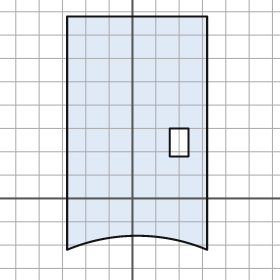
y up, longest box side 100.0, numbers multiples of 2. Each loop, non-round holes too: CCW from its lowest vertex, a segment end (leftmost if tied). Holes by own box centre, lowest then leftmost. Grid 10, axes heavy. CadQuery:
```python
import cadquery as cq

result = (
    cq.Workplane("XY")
    .moveTo(-28.0, -22.0)
    .threePointArc((2.0, -16.0), (32.0, -22.0))
    .lineTo(32.0, 78.0)
    .lineTo(-28.0, 78.0)
    .close()
    .moveTo(16.0, 18.0)
    .lineTo(24.0, 18.0)
    .lineTo(24.0, 30.0)
    .lineTo(16.0, 30.0)
    .close()
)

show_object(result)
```